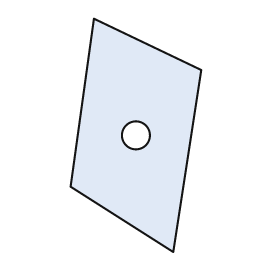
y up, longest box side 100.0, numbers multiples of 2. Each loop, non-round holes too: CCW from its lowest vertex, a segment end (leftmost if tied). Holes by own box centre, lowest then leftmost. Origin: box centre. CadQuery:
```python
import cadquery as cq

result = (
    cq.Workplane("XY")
    .moveTo(16.0, -50.0)
    .lineTo(28.0, 28.0)
    .lineTo(-18.0, 50.0)
    .lineTo(-28.0, -22.0)
    .close()
    .moveTo(0.0, 0.0)
    .circle(6.0)
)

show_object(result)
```